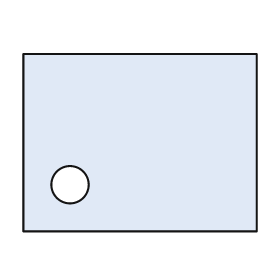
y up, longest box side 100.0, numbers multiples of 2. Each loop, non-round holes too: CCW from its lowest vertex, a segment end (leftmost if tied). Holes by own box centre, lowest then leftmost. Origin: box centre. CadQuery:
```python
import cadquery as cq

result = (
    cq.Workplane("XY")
    .moveTo(-50.0, -38.0)
    .lineTo(50.0, -38.0)
    .lineTo(50.0, 38.0)
    .lineTo(-50.0, 38.0)
    .close()
    .moveTo(-30.0, -18.0)
    .circle(8.0)
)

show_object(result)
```